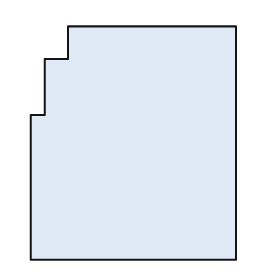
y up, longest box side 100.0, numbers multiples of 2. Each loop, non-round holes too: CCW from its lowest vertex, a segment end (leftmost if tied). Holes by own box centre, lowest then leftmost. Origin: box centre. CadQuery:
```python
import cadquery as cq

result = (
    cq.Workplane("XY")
    .moveTo(-44.0, -50.0)
    .lineTo(44.0, -50.0)
    .lineTo(44.0, 50.0)
    .lineTo(-28.0, 50.0)
    .lineTo(-28.0, 36.0)
    .lineTo(-38.0, 36.0)
    .lineTo(-38.0, 12.0)
    .lineTo(-44.0, 12.0)
    .close()
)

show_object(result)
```